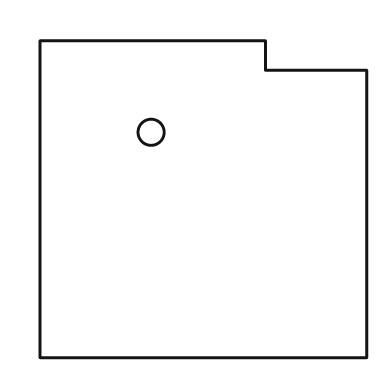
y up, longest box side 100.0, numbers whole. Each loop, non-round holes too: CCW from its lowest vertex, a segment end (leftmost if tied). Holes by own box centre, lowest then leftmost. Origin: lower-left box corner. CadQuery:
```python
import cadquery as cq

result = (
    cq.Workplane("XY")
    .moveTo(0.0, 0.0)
    .lineTo(100.0, 0.0)
    .lineTo(100.0, 88.0)
    .lineTo(69.0, 88.0)
    .lineTo(69.0, 97.0)
    .lineTo(0.0, 97.0)
    .close()
    .moveTo(34.0, 69.0)
    .circle(4.0)
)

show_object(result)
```